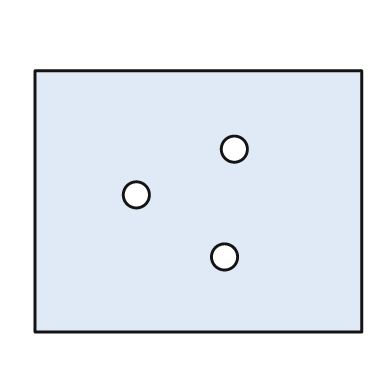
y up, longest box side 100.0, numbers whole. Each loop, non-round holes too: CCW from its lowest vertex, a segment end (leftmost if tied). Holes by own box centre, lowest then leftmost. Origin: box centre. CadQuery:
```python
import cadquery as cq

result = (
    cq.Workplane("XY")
    .moveTo(-50.0, -40.0)
    .lineTo(50.0, -40.0)
    .lineTo(50.0, 40.0)
    .lineTo(-50.0, 40.0)
    .close()
    .moveTo(8.0, -17.0)
    .circle(4.0)
    .moveTo(-19.0, 2.0)
    .circle(4.0)
    .moveTo(11.0, 16.0)
    .circle(4.0)
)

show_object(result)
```